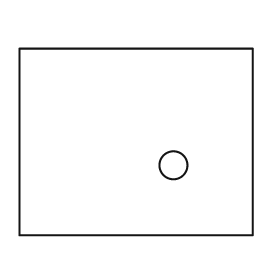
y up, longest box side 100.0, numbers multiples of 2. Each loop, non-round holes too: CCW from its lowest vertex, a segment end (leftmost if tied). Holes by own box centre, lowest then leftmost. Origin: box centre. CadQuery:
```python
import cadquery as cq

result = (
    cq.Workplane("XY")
    .moveTo(-50.0, -40.0)
    .lineTo(50.0, -40.0)
    .lineTo(50.0, 40.0)
    .lineTo(-50.0, 40.0)
    .close()
    .moveTo(16.0, -10.0)
    .circle(6.0)
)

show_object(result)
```